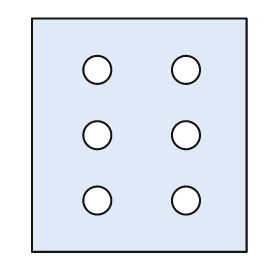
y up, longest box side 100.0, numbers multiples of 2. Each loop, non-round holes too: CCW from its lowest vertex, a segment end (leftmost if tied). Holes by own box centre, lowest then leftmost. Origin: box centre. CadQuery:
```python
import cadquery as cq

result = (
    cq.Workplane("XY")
    .moveTo(-46.0, -50.0)
    .lineTo(46.0, -50.0)
    .lineTo(46.0, 50.0)
    .lineTo(-46.0, 50.0)
    .close()
    .moveTo(-18.0, -28.0)
    .circle(6.0)
    .moveTo(20.0, -28.0)
    .circle(6.0)
    .moveTo(-18.0, 0.0)
    .circle(6.0)
    .moveTo(20.0, 0.0)
    .circle(6.0)
    .moveTo(-18.0, 28.0)
    .circle(6.0)
    .moveTo(20.0, 28.0)
    .circle(6.0)
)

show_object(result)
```